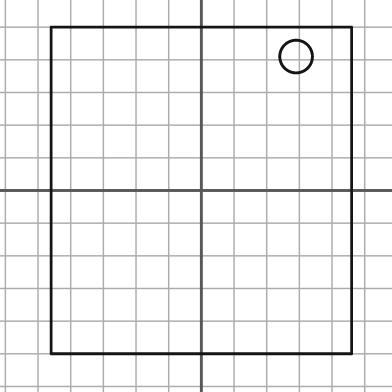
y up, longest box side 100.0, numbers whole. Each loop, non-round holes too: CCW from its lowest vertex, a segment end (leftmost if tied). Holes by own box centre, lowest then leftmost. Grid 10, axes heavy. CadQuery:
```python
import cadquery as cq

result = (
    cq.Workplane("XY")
    .moveTo(-46.0, -50.0)
    .lineTo(46.0, -50.0)
    .lineTo(46.0, 50.0)
    .lineTo(-46.0, 50.0)
    .close()
    .moveTo(29.0, 41.0)
    .circle(5.0)
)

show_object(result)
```